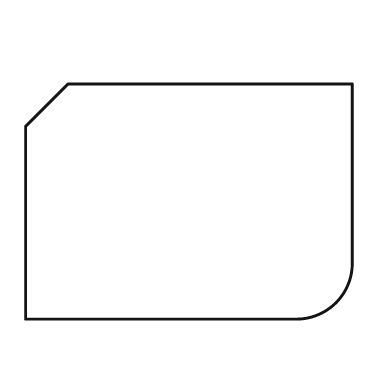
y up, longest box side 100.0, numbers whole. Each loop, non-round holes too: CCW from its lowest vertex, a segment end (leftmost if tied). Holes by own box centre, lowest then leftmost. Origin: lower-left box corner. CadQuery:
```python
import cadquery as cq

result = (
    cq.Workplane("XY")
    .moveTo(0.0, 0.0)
    .lineTo(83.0, 0.0)
    .threePointArc((95.0, 5.0), (100.0, 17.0))
    .lineTo(100.0, 72.0)
    .lineTo(13.0, 72.0)
    .lineTo(0.0, 59.0)
    .close()
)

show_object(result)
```